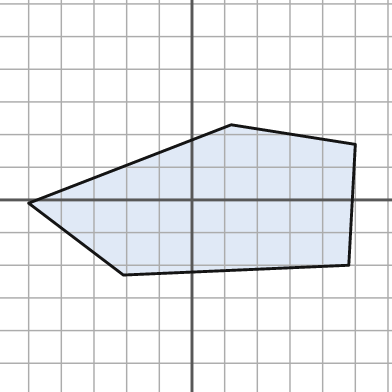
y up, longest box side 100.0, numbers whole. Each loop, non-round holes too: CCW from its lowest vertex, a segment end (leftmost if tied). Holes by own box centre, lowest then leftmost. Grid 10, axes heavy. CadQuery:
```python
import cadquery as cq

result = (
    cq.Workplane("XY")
    .moveTo(-21.0, -23.0)
    .lineTo(48.0, -20.0)
    .lineTo(50.0, 17.0)
    .lineTo(12.0, 23.0)
    .lineTo(-50.0, -1.0)
    .close()
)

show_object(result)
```